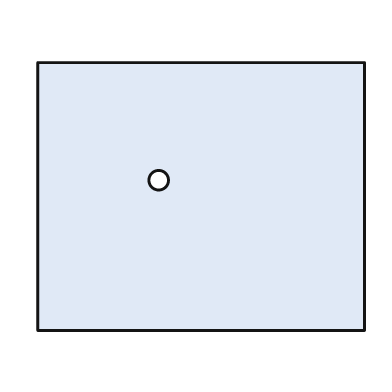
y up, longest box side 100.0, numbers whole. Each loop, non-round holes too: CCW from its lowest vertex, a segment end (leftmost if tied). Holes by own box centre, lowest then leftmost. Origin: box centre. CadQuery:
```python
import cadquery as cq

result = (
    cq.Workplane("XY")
    .moveTo(-50.0, -41.0)
    .lineTo(50.0, -41.0)
    .lineTo(50.0, 41.0)
    .lineTo(-50.0, 41.0)
    .close()
    .moveTo(-13.0, 5.0)
    .circle(3.0)
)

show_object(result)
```